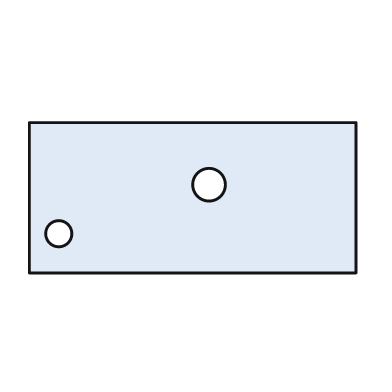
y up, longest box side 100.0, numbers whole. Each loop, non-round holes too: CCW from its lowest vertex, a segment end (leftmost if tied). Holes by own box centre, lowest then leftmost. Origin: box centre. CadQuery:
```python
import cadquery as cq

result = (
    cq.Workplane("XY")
    .moveTo(-50.0, -23.0)
    .lineTo(50.0, -23.0)
    .lineTo(50.0, 23.0)
    .lineTo(-50.0, 23.0)
    .close()
    .moveTo(-41.0, -11.0)
    .circle(4.0)
    .moveTo(5.0, 4.0)
    .circle(5.0)
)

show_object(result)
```